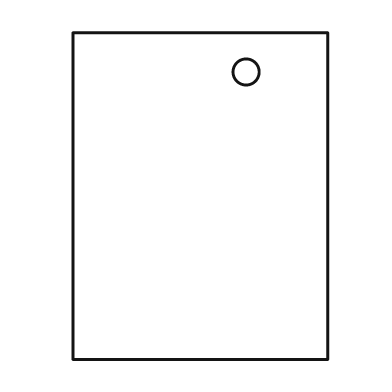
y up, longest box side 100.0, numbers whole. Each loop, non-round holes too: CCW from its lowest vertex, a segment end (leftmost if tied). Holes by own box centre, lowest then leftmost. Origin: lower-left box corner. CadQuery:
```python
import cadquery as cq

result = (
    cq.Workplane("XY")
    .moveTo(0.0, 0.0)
    .lineTo(78.0, 0.0)
    .lineTo(78.0, 100.0)
    .lineTo(0.0, 100.0)
    .close()
    .moveTo(53.0, 88.0)
    .circle(4.0)
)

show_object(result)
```